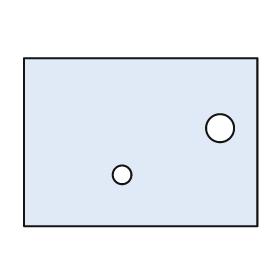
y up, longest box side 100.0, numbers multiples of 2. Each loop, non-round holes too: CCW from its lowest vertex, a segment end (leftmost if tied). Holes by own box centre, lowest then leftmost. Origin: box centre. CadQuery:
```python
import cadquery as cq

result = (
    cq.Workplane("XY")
    .moveTo(-50.0, -36.0)
    .lineTo(50.0, -36.0)
    .lineTo(50.0, 36.0)
    .lineTo(-50.0, 36.0)
    .close()
    .moveTo(-8.0, -14.0)
    .circle(4.0)
    .moveTo(34.0, 6.0)
    .circle(6.0)
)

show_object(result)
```